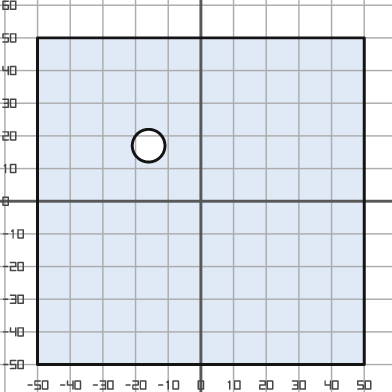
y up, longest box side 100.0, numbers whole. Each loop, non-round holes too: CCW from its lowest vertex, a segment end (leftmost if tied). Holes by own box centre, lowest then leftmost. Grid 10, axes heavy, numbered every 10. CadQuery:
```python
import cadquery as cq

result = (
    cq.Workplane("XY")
    .moveTo(-50.0, -50.0)
    .lineTo(50.0, -50.0)
    .lineTo(50.0, 50.0)
    .lineTo(-50.0, 50.0)
    .close()
    .moveTo(-16.0, 17.0)
    .circle(5.0)
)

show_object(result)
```